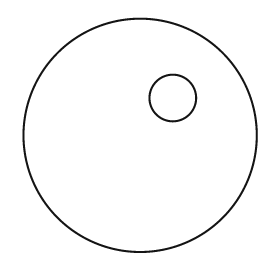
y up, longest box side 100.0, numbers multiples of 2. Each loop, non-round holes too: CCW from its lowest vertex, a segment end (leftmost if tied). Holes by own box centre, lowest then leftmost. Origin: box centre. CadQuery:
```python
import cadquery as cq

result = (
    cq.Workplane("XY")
    .moveTo(0.0, 0.0)
    .circle(50.0)
    .moveTo(14.0, 16.0)
    .circle(10.0)
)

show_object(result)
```